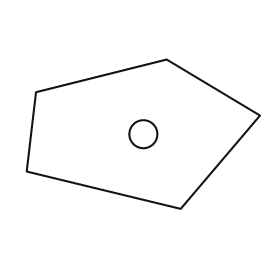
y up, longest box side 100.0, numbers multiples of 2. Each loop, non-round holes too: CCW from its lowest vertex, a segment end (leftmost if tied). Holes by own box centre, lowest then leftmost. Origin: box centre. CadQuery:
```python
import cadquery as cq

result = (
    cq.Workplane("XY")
    .moveTo(16.0, -32.0)
    .lineTo(50.0, 8.0)
    .lineTo(10.0, 32.0)
    .lineTo(-46.0, 18.0)
    .lineTo(-50.0, -16.0)
    .close()
    .moveTo(0.0, 0.0)
    .circle(6.0)
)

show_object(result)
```